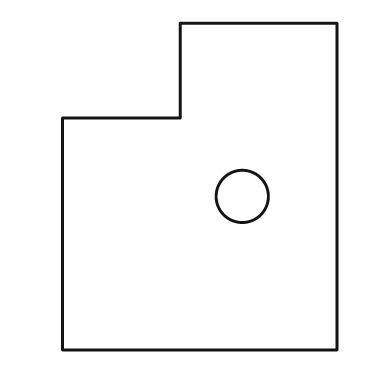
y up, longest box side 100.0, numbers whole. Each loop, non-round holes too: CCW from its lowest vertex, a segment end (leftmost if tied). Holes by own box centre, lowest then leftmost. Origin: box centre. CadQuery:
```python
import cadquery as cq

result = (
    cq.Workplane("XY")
    .moveTo(-42.0, -50.0)
    .lineTo(42.0, -50.0)
    .lineTo(42.0, 50.0)
    .lineTo(-6.0, 50.0)
    .lineTo(-6.0, 21.0)
    .lineTo(-42.0, 21.0)
    .close()
    .moveTo(13.0, -3.0)
    .circle(8.0)
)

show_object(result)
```